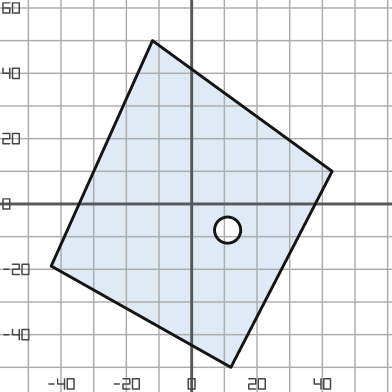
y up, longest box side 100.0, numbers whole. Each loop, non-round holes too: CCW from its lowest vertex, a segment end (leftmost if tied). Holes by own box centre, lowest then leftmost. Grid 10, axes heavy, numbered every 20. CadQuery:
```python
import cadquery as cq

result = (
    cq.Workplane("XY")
    .moveTo(12.0, -50.0)
    .lineTo(43.0, 10.0)
    .lineTo(-12.0, 50.0)
    .lineTo(-43.0, -19.0)
    .close()
    .moveTo(11.0, -8.0)
    .circle(4.0)
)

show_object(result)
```